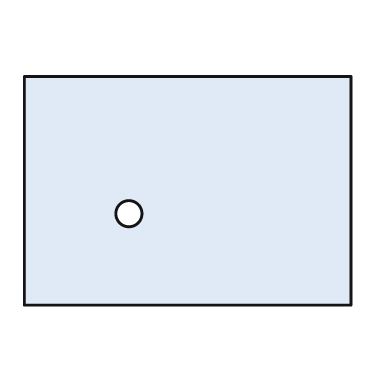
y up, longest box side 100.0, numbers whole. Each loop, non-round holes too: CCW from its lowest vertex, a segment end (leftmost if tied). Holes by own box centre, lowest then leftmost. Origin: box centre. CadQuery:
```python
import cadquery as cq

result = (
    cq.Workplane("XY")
    .moveTo(-50.0, -35.0)
    .lineTo(50.0, -35.0)
    .lineTo(50.0, 35.0)
    .lineTo(-50.0, 35.0)
    .close()
    .moveTo(-18.0, -7.0)
    .circle(4.0)
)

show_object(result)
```